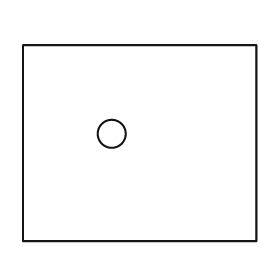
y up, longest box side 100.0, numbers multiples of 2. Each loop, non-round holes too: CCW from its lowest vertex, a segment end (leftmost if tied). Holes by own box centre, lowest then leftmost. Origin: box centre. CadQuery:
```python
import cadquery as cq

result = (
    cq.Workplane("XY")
    .moveTo(-50.0, -42.0)
    .lineTo(50.0, -42.0)
    .lineTo(50.0, 42.0)
    .lineTo(-50.0, 42.0)
    .close()
    .moveTo(-12.0, 4.0)
    .circle(6.0)
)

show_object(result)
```